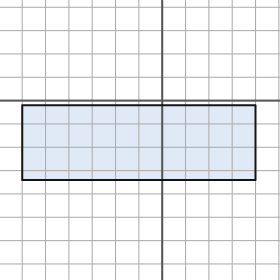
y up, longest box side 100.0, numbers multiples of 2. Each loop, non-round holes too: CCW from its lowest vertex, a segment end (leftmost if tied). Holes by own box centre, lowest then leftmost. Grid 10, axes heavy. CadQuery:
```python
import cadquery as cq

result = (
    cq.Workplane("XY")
    .moveTo(-60.0, -34.0)
    .lineTo(40.0, -34.0)
    .lineTo(40.0, -2.0)
    .lineTo(-60.0, -2.0)
    .close()
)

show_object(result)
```